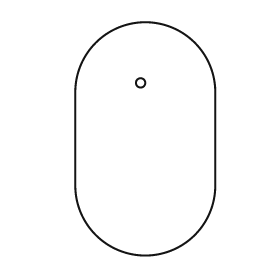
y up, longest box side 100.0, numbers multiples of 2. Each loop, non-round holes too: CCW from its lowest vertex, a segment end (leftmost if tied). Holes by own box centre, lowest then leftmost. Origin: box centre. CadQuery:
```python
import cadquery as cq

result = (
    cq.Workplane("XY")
    .moveTo(-30.0, -20.0)
    .threePointArc((0.0, -50.0), (30.0, -20.0))
    .lineTo(30.0, 20.0)
    .threePointArc((0.0, 50.0), (-30.0, 20.0))
    .close()
    .moveTo(-2.0, 24.0)
    .circle(2.0)
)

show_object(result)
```